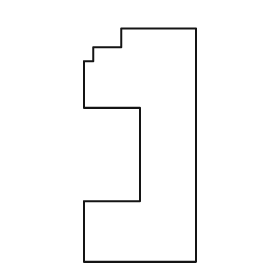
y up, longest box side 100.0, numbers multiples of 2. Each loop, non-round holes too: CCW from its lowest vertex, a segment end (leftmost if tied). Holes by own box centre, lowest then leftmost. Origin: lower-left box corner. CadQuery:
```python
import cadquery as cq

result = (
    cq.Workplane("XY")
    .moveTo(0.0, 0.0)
    .lineTo(48.0, 0.0)
    .lineTo(48.0, 100.0)
    .lineTo(16.0, 100.0)
    .lineTo(16.0, 92.0)
    .lineTo(4.0, 92.0)
    .lineTo(4.0, 86.0)
    .lineTo(0.0, 86.0)
    .lineTo(0.0, 66.0)
    .lineTo(24.0, 66.0)
    .lineTo(24.0, 26.0)
    .lineTo(0.0, 26.0)
    .close()
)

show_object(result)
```